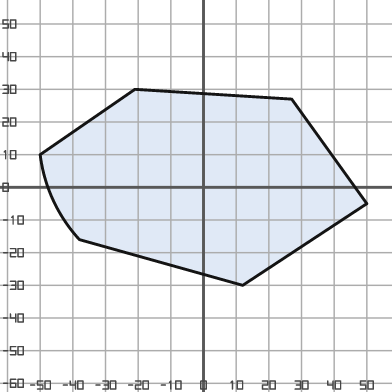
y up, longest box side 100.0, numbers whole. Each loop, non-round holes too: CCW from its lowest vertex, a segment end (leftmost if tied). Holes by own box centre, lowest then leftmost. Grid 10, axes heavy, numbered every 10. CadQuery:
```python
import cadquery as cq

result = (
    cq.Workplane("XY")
    .moveTo(12.0, -30.0)
    .lineTo(50.0, -5.0)
    .lineTo(27.0, 27.0)
    .lineTo(-21.0, 30.0)
    .lineTo(-50.0, 10.0)
    .threePointArc((-46.0, -4.0), (-38.0, -16.0))
    .close()
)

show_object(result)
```